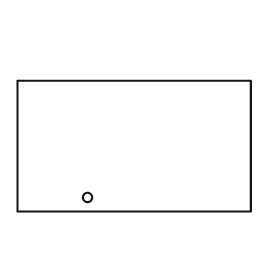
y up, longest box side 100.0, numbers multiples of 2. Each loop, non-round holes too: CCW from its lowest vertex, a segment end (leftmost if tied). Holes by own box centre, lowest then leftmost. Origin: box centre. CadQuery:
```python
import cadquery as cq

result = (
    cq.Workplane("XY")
    .moveTo(-50.0, -28.0)
    .lineTo(50.0, -28.0)
    .lineTo(50.0, 28.0)
    .lineTo(-50.0, 28.0)
    .close()
    .moveTo(-20.0, -22.0)
    .circle(2.0)
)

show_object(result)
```